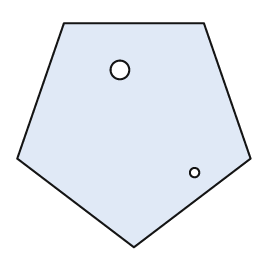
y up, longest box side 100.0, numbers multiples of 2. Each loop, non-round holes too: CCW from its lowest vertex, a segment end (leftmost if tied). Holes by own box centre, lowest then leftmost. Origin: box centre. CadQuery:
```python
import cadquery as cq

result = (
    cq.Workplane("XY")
    .moveTo(0.0, -48.0)
    .lineTo(50.0, -10.0)
    .lineTo(30.0, 48.0)
    .lineTo(-30.0, 48.0)
    .lineTo(-50.0, -10.0)
    .close()
    .moveTo(26.0, -16.0)
    .circle(2.0)
    .moveTo(-6.0, 28.0)
    .circle(4.0)
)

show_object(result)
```